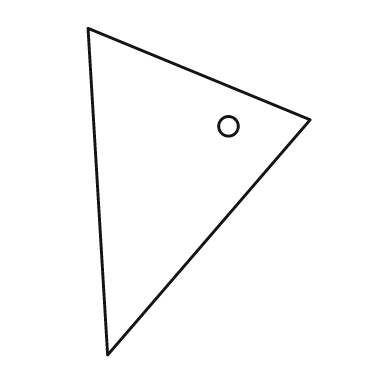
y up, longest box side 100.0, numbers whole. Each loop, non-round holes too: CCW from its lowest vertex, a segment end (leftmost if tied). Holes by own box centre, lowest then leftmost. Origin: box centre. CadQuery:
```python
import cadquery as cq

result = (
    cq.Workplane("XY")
    .moveTo(-28.0, -50.0)
    .lineTo(34.0, 22.0)
    .lineTo(-34.0, 50.0)
    .close()
    .moveTo(9.0, 20.0)
    .circle(3.0)
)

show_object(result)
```